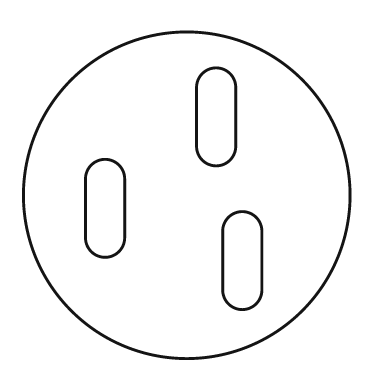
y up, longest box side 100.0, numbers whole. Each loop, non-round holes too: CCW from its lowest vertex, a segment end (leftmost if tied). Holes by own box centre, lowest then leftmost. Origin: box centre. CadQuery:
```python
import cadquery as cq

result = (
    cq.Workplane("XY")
    .moveTo(0.0, 0.0)
    .circle(50.0)
    .moveTo(11.0, -29.0)
    .threePointArc((17.0, -35.0), (23.0, -29.0))
    .lineTo(23.0, -11.0)
    .threePointArc((17.0, -5.0), (11.0, -11.0))
    .close()
    .moveTo(-31.0, -13.0)
    .threePointArc((-25.0, -19.0), (-19.0, -13.0))
    .lineTo(-19.0, 5.0)
    .threePointArc((-25.0, 11.0), (-31.0, 5.0))
    .close()
    .moveTo(3.0, 15.0)
    .threePointArc((9.0, 9.0), (15.0, 15.0))
    .lineTo(15.0, 33.0)
    .threePointArc((9.0, 39.0), (3.0, 33.0))
    .close()
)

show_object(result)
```